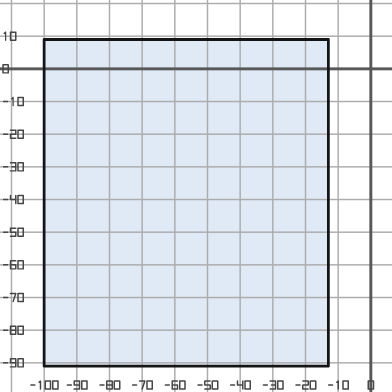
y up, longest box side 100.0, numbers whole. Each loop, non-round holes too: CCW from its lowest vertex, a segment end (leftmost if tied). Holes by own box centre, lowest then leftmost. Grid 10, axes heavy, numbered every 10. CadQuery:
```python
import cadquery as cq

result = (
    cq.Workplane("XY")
    .moveTo(-100.0, -91.0)
    .lineTo(-13.0, -91.0)
    .lineTo(-13.0, 9.0)
    .lineTo(-100.0, 9.0)
    .close()
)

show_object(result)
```